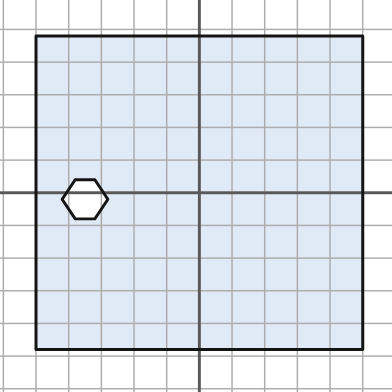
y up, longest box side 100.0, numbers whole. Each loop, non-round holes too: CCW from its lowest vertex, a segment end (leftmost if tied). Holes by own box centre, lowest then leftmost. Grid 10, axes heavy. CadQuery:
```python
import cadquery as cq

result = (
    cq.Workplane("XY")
    .moveTo(-50.0, -48.0)
    .lineTo(50.0, -48.0)
    .lineTo(50.0, 48.0)
    .lineTo(-50.0, 48.0)
    .close()
    .moveTo(-38.0, -8.0)
    .lineTo(-32.0, -8.0)
    .lineTo(-28.0, -2.0)
    .lineTo(-32.0, 4.0)
    .lineTo(-38.0, 4.0)
    .lineTo(-42.0, -2.0)
    .close()
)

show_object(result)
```